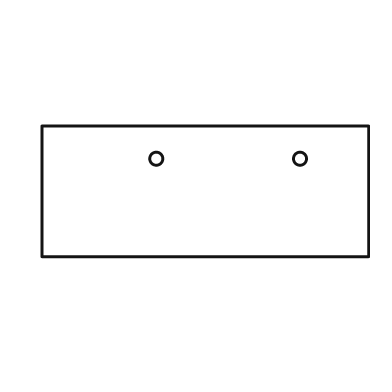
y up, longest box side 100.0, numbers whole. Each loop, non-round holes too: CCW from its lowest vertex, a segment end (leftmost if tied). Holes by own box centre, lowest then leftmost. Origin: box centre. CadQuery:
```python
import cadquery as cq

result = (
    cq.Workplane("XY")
    .moveTo(-50.0, -20.0)
    .lineTo(50.0, -20.0)
    .lineTo(50.0, 20.0)
    .lineTo(-50.0, 20.0)
    .close()
    .moveTo(-15.0, 10.0)
    .circle(2.0)
    .moveTo(29.0, 10.0)
    .circle(2.0)
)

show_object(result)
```